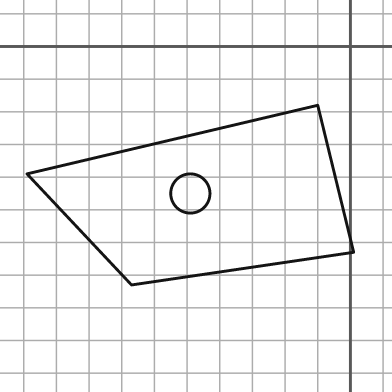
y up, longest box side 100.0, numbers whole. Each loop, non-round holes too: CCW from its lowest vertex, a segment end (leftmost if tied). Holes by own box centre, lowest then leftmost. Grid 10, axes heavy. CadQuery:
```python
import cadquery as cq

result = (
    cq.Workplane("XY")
    .moveTo(-67.0, -73.0)
    .lineTo(1.0, -63.0)
    .lineTo(-10.0, -18.0)
    .lineTo(-99.0, -39.0)
    .close()
    .moveTo(-49.0, -45.0)
    .circle(6.0)
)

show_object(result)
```